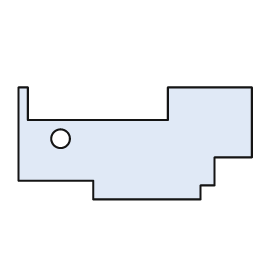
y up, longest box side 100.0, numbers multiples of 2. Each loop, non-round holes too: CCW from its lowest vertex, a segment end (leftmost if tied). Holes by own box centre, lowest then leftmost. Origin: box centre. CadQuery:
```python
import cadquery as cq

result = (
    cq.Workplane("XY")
    .moveTo(-18.0, -24.0)
    .lineTo(28.0, -24.0)
    .lineTo(28.0, -18.0)
    .lineTo(34.0, -18.0)
    .lineTo(34.0, -6.0)
    .lineTo(50.0, -6.0)
    .lineTo(50.0, 24.0)
    .lineTo(14.0, 24.0)
    .lineTo(14.0, 10.0)
    .lineTo(-46.0, 10.0)
    .lineTo(-46.0, 24.0)
    .lineTo(-50.0, 24.0)
    .lineTo(-50.0, -16.0)
    .lineTo(-18.0, -16.0)
    .close()
    .moveTo(-32.0, 2.0)
    .circle(4.0)
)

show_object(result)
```